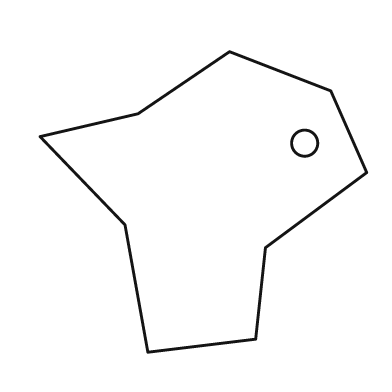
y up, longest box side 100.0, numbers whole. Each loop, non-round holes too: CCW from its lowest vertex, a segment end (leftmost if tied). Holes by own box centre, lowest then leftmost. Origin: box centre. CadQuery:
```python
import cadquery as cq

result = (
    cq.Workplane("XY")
    .moveTo(-17.0, -46.0)
    .lineTo(16.0, -42.0)
    .lineTo(19.0, -14.0)
    .lineTo(50.0, 9.0)
    .lineTo(39.0, 34.0)
    .lineTo(8.0, 46.0)
    .lineTo(-20.0, 27.0)
    .lineTo(-50.0, 20.0)
    .lineTo(-24.0, -7.0)
    .close()
    .moveTo(31.0, 18.0)
    .circle(4.0)
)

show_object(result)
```